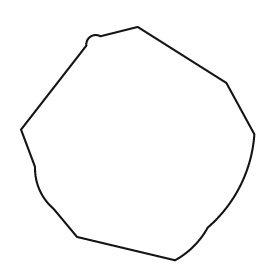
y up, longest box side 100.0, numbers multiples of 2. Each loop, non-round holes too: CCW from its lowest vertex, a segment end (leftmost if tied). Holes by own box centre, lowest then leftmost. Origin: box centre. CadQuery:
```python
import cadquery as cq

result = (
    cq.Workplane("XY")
    .moveTo(16.0, -50.0)
    .threePointArc((24.0, -44.0), (30.0, -36.0))
    .threePointArc((44.0, -18.0), (50.0, 4.0))
    .lineTo(38.0, 26.0)
    .lineTo(0.0, 50.0)
    .lineTo(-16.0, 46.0)
    .threePointArc((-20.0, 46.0), (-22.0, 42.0))
    .lineTo(-50.0, 6.0)
    .lineTo(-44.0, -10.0)
    .threePointArc((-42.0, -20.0), (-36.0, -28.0))
    .lineTo(-26.0, -40.0)
    .close()
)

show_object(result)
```